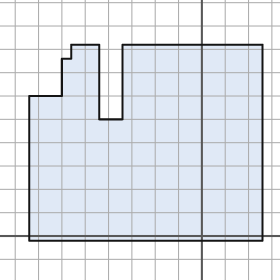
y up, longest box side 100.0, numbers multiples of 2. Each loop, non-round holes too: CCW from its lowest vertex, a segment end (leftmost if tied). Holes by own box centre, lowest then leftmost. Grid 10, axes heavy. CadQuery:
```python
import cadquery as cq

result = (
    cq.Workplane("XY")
    .moveTo(-74.0, -2.0)
    .lineTo(26.0, -2.0)
    .lineTo(26.0, 82.0)
    .lineTo(-34.0, 82.0)
    .lineTo(-34.0, 50.0)
    .lineTo(-44.0, 50.0)
    .lineTo(-44.0, 82.0)
    .lineTo(-56.0, 82.0)
    .lineTo(-56.0, 76.0)
    .lineTo(-60.0, 76.0)
    .lineTo(-60.0, 60.0)
    .lineTo(-74.0, 60.0)
    .close()
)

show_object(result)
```